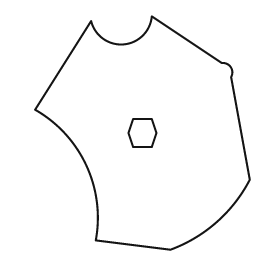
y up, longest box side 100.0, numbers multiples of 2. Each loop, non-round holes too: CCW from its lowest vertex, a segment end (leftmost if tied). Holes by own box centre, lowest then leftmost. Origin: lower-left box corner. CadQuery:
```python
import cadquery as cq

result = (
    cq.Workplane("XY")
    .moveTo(58.0, 0.0)
    .threePointArc((78.0, 12.0), (92.0, 30.0))
    .lineTo(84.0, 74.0)
    .threePointArc((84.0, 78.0), (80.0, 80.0))
    .lineTo(50.0, 100.0)
    .threePointArc((38.0, 88.0), (24.0, 98.0))
    .lineTo(0.0, 60.0)
    .threePointArc((22.0, 36.0), (26.0, 4.0))
    .close()
    .moveTo(42.0, 44.0)
    .lineTo(50.0, 44.0)
    .lineTo(52.0, 50.0)
    .lineTo(50.0, 56.0)
    .lineTo(42.0, 56.0)
    .lineTo(40.0, 50.0)
    .close()
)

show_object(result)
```